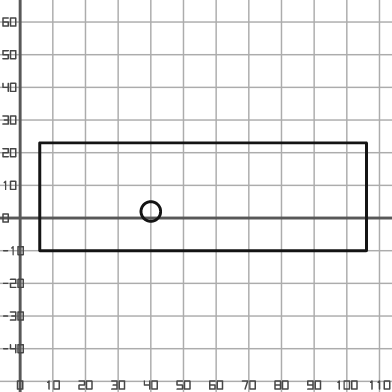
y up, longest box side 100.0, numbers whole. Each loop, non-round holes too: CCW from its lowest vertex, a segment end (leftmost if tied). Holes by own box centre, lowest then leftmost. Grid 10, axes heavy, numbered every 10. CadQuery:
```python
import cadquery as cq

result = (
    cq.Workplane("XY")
    .moveTo(6.0, -10.0)
    .lineTo(106.0, -10.0)
    .lineTo(106.0, 23.0)
    .lineTo(6.0, 23.0)
    .close()
    .moveTo(40.0, 2.0)
    .circle(3.0)
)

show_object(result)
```